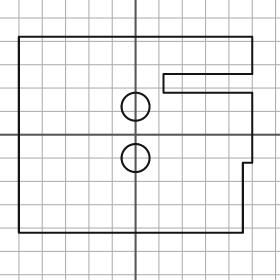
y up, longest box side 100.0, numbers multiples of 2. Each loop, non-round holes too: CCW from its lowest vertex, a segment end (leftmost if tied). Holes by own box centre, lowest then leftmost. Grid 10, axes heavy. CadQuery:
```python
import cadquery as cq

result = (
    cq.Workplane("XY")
    .moveTo(-50.0, -42.0)
    .lineTo(46.0, -42.0)
    .lineTo(46.0, -12.0)
    .lineTo(50.0, -12.0)
    .lineTo(50.0, 18.0)
    .lineTo(12.0, 18.0)
    .lineTo(12.0, 26.0)
    .lineTo(50.0, 26.0)
    .lineTo(50.0, 42.0)
    .lineTo(-50.0, 42.0)
    .close()
    .moveTo(0.0, -10.0)
    .circle(6.0)
    .moveTo(0.0, 12.0)
    .circle(6.0)
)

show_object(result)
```